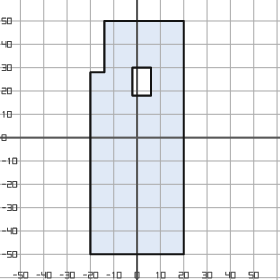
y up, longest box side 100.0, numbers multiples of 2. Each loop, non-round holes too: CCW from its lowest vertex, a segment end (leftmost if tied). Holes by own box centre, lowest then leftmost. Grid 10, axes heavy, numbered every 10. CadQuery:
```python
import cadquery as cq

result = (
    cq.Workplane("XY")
    .moveTo(-20.0, -50.0)
    .lineTo(20.0, -50.0)
    .lineTo(20.0, 50.0)
    .lineTo(-14.0, 50.0)
    .lineTo(-14.0, 28.0)
    .lineTo(-20.0, 28.0)
    .close()
    .moveTo(-2.0, 18.0)
    .lineTo(6.0, 18.0)
    .lineTo(6.0, 30.0)
    .lineTo(-2.0, 30.0)
    .close()
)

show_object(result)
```